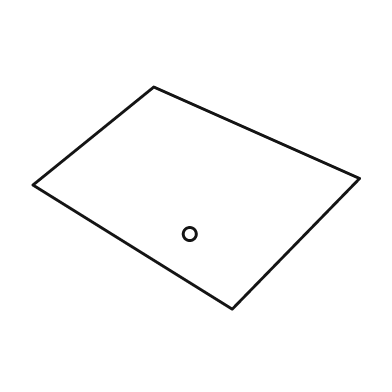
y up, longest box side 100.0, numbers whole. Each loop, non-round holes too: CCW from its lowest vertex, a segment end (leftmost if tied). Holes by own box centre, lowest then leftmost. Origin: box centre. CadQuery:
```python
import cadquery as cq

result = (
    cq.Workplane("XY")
    .moveTo(11.0, -34.0)
    .lineTo(50.0, 6.0)
    .lineTo(-13.0, 34.0)
    .lineTo(-50.0, 4.0)
    .close()
    .moveTo(-2.0, -11.0)
    .circle(2.0)
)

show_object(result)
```